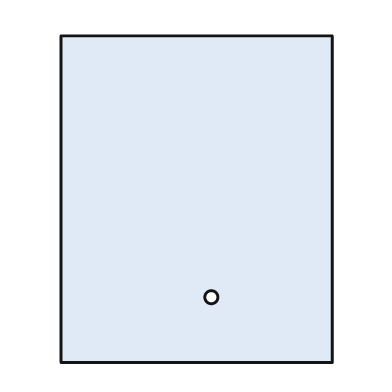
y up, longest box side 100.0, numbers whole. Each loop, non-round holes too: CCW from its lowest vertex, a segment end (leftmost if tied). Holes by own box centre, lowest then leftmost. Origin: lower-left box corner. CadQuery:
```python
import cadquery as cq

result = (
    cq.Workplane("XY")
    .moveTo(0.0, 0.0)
    .lineTo(83.0, 0.0)
    .lineTo(83.0, 100.0)
    .lineTo(0.0, 100.0)
    .close()
    .moveTo(46.0, 20.0)
    .circle(2.0)
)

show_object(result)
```